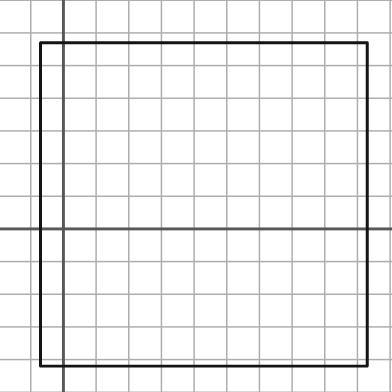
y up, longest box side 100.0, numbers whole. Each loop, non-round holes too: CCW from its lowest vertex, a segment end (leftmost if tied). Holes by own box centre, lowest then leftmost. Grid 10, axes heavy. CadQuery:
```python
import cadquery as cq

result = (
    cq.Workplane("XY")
    .moveTo(-7.0, -42.0)
    .lineTo(93.0, -42.0)
    .lineTo(93.0, 57.0)
    .lineTo(-7.0, 57.0)
    .close()
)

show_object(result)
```